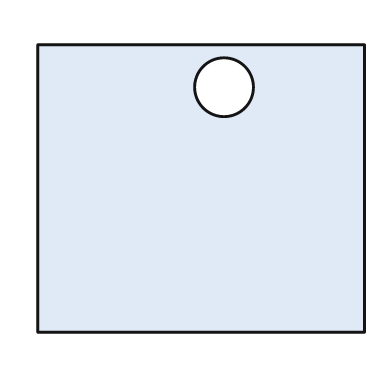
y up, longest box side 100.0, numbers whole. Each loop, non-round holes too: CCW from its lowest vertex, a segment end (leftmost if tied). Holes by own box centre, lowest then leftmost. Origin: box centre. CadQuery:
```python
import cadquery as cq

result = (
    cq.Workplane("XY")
    .moveTo(-50.0, -44.0)
    .lineTo(50.0, -44.0)
    .lineTo(50.0, 44.0)
    .lineTo(-50.0, 44.0)
    .close()
    .moveTo(7.0, 31.0)
    .circle(9.0)
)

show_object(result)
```